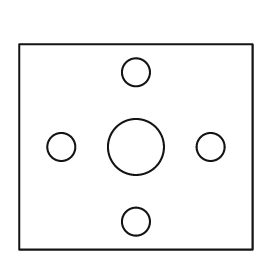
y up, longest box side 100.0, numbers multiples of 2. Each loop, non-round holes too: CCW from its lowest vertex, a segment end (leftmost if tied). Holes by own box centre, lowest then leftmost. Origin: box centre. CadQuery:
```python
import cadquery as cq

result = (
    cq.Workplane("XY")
    .moveTo(-50.0, -44.0)
    .lineTo(50.0, -44.0)
    .lineTo(50.0, 44.0)
    .lineTo(-50.0, 44.0)
    .close()
    .moveTo(0.0, -32.0)
    .circle(6.0)
    .moveTo(-32.0, 0.0)
    .circle(6.0)
    .moveTo(0.0, 0.0)
    .circle(12.0)
    .moveTo(32.0, 0.0)
    .circle(6.0)
    .moveTo(0.0, 32.0)
    .circle(6.0)
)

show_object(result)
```